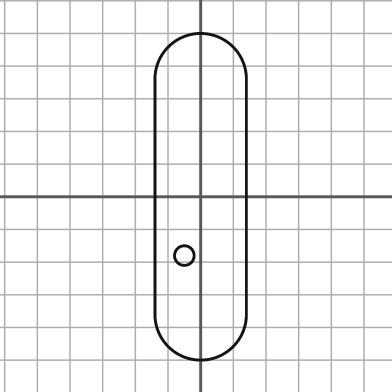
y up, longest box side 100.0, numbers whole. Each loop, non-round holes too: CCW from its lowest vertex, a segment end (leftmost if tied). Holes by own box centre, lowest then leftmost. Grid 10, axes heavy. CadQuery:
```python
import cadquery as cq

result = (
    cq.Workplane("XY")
    .moveTo(-14.0, -36.0)
    .threePointArc((0.0, -50.0), (14.0, -36.0))
    .lineTo(14.0, 36.0)
    .threePointArc((0.0, 50.0), (-14.0, 36.0))
    .close()
    .moveTo(-5.0, -18.0)
    .circle(3.0)
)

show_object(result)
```